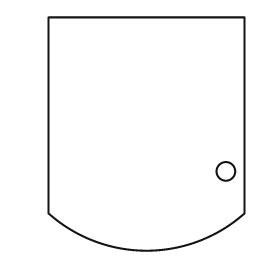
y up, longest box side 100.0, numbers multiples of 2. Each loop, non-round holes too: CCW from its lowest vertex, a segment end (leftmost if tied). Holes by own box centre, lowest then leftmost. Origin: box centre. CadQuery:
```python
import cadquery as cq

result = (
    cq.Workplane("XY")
    .moveTo(-42.0, -34.0)
    .threePointArc((0.0, -50.0), (42.0, -34.0))
    .lineTo(42.0, 50.0)
    .lineTo(-42.0, 50.0)
    .close()
    .moveTo(34.0, -16.0)
    .circle(4.0)
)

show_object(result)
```